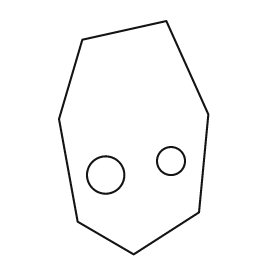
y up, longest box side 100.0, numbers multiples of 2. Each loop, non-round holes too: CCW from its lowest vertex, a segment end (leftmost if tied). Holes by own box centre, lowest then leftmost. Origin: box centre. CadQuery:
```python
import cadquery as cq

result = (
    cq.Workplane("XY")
    .moveTo(0.0, -50.0)
    .lineTo(28.0, -32.0)
    .lineTo(32.0, 10.0)
    .lineTo(14.0, 50.0)
    .lineTo(-22.0, 42.0)
    .lineTo(-32.0, 8.0)
    .lineTo(-24.0, -36.0)
    .close()
    .moveTo(-12.0, -16.0)
    .circle(8.0)
    .moveTo(16.0, -10.0)
    .circle(6.0)
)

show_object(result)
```